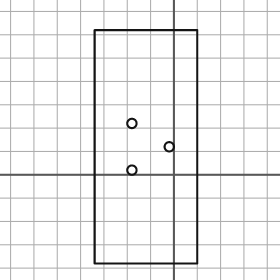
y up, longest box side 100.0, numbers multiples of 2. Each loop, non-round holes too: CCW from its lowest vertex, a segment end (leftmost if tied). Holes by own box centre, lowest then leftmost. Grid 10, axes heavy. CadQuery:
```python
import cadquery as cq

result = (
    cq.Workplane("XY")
    .moveTo(-34.0, -38.0)
    .lineTo(10.0, -38.0)
    .lineTo(10.0, 62.0)
    .lineTo(-34.0, 62.0)
    .close()
    .moveTo(-18.0, 2.0)
    .circle(2.0)
    .moveTo(-2.0, 12.0)
    .circle(2.0)
    .moveTo(-18.0, 22.0)
    .circle(2.0)
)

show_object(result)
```